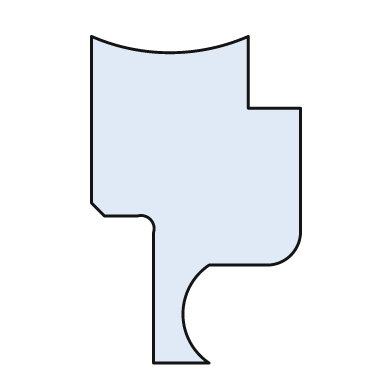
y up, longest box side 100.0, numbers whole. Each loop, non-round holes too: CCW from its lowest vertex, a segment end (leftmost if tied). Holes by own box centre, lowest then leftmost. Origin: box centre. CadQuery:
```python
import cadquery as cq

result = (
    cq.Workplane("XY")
    .moveTo(-13.0, -50.0)
    .lineTo(4.0, -50.0)
    .threePointArc((-4.0, -35.0), (4.0, -20.0))
    .lineTo(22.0, -20.0)
    .threePointArc((29.0, -17.0), (32.0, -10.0))
    .lineTo(32.0, 28.0)
    .lineTo(16.0, 28.0)
    .lineTo(16.0, 50.0)
    .threePointArc((-8.0, 45.0), (-32.0, 50.0))
    .lineTo(-32.0, -1.0)
    .lineTo(-28.0, -5.0)
    .lineTo(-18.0, -5.0)
    .threePointArc((-14.0, -6.0), (-13.0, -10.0))
    .close()
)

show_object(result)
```